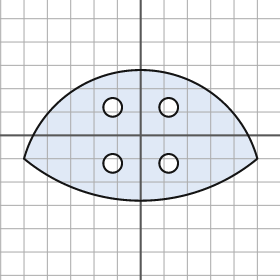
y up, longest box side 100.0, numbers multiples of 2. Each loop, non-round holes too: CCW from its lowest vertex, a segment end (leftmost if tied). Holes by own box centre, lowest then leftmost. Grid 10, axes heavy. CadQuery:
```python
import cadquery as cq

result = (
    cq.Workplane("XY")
    .moveTo(-50.0, -10.0)
    .threePointArc((0.0, -28.0), (50.0, -10.0))
    .threePointArc((0.0, 28.0), (-50.0, -10.0))
    .close()
    .moveTo(-12.0, -12.0)
    .circle(4.0)
    .moveTo(12.0, -12.0)
    .circle(4.0)
    .moveTo(-12.0, 12.0)
    .circle(4.0)
    .moveTo(12.0, 12.0)
    .circle(4.0)
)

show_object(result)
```